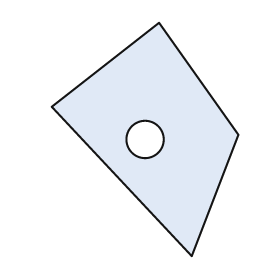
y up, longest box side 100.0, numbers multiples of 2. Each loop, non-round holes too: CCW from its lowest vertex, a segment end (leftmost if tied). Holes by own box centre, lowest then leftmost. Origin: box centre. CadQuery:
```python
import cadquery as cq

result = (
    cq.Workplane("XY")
    .moveTo(20.0, -50.0)
    .lineTo(40.0, 2.0)
    .lineTo(6.0, 50.0)
    .lineTo(-40.0, 14.0)
    .close()
    .moveTo(0.0, 0.0)
    .circle(8.0)
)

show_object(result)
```